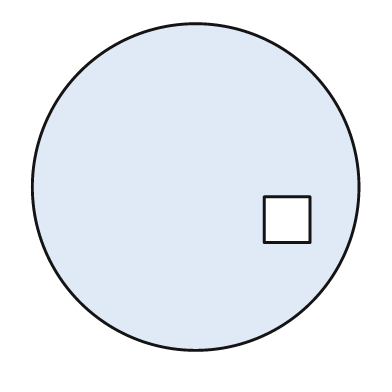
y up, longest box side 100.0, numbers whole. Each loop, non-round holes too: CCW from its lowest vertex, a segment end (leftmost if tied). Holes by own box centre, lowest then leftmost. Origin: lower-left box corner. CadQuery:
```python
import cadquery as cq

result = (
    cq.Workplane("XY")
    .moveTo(50.0, 50.0)
    .circle(50.0)
    .moveTo(71.0, 33.0)
    .lineTo(85.0, 33.0)
    .lineTo(85.0, 47.0)
    .lineTo(71.0, 47.0)
    .close()
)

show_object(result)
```